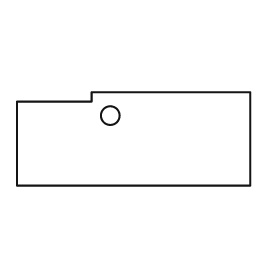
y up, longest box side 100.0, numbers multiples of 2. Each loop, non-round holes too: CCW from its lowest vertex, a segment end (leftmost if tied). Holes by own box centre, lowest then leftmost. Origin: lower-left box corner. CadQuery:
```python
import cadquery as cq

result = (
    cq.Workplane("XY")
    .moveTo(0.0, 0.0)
    .lineTo(100.0, 0.0)
    .lineTo(100.0, 40.0)
    .lineTo(32.0, 40.0)
    .lineTo(32.0, 36.0)
    .lineTo(0.0, 36.0)
    .close()
    .moveTo(40.0, 30.0)
    .circle(4.0)
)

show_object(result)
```